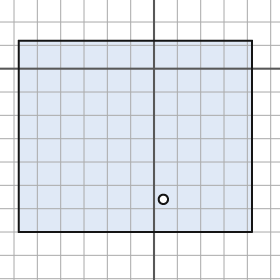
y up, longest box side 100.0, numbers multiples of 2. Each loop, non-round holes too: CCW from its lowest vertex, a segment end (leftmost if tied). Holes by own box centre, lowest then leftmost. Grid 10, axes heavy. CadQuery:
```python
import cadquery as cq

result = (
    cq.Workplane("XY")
    .moveTo(-58.0, -70.0)
    .lineTo(42.0, -70.0)
    .lineTo(42.0, 12.0)
    .lineTo(-58.0, 12.0)
    .close()
    .moveTo(4.0, -56.0)
    .circle(2.0)
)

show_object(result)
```